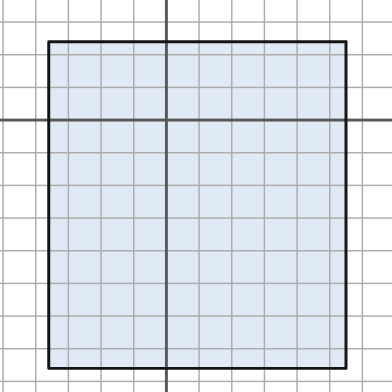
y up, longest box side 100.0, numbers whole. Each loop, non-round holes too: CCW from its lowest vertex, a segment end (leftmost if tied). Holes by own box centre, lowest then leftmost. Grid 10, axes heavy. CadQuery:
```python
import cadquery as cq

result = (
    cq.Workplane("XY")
    .moveTo(-36.0, -76.0)
    .lineTo(55.0, -76.0)
    .lineTo(55.0, 24.0)
    .lineTo(-36.0, 24.0)
    .close()
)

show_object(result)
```